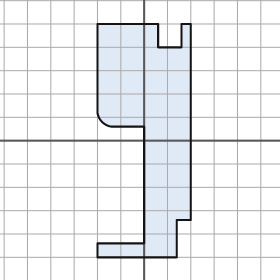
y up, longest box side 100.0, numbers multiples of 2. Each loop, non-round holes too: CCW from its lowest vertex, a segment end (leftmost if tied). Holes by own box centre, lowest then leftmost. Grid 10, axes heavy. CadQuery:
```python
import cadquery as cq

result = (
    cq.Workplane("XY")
    .moveTo(-20.0, -50.0)
    .lineTo(14.0, -50.0)
    .lineTo(14.0, -34.0)
    .lineTo(20.0, -34.0)
    .lineTo(20.0, 50.0)
    .lineTo(16.0, 50.0)
    .lineTo(16.0, 40.0)
    .lineTo(6.0, 40.0)
    .lineTo(6.0, 50.0)
    .lineTo(-20.0, 50.0)
    .lineTo(-20.0, 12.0)
    .threePointArc((-18.0, 8.0), (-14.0, 6.0))
    .lineTo(0.0, 6.0)
    .lineTo(0.0, -44.0)
    .lineTo(-20.0, -44.0)
    .close()
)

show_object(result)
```